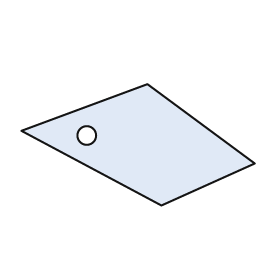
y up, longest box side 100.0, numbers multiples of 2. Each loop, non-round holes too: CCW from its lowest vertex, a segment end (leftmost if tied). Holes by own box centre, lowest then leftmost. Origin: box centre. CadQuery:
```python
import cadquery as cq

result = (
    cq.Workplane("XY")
    .moveTo(10.0, -26.0)
    .lineTo(50.0, -8.0)
    .lineTo(4.0, 26.0)
    .lineTo(-50.0, 6.0)
    .close()
    .moveTo(-22.0, 4.0)
    .circle(4.0)
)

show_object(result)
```